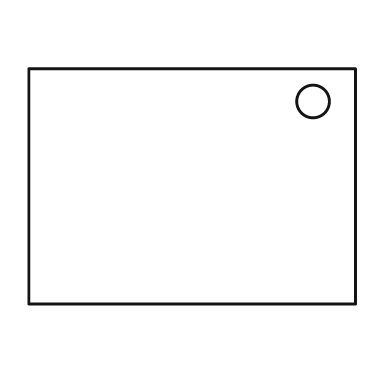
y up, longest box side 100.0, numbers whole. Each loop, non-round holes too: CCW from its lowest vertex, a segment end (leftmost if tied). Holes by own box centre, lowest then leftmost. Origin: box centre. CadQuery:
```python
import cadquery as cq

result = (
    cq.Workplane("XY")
    .moveTo(-50.0, -36.0)
    .lineTo(50.0, -36.0)
    .lineTo(50.0, 36.0)
    .lineTo(-50.0, 36.0)
    .close()
    .moveTo(37.0, 26.0)
    .circle(5.0)
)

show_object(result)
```